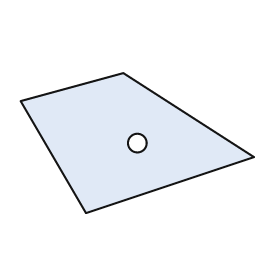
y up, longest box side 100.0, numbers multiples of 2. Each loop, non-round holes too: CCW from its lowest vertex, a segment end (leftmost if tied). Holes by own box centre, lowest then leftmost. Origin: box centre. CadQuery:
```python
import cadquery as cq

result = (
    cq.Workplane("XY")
    .moveTo(-22.0, -30.0)
    .lineTo(50.0, -6.0)
    .lineTo(-6.0, 30.0)
    .lineTo(-50.0, 18.0)
    .close()
    .moveTo(0.0, 0.0)
    .circle(4.0)
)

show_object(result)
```